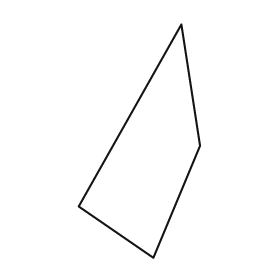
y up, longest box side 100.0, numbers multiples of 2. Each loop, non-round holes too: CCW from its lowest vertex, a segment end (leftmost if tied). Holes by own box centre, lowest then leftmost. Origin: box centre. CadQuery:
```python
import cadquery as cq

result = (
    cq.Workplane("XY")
    .moveTo(6.0, -50.0)
    .lineTo(26.0, -2.0)
    .lineTo(18.0, 50.0)
    .lineTo(-26.0, -28.0)
    .close()
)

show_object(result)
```